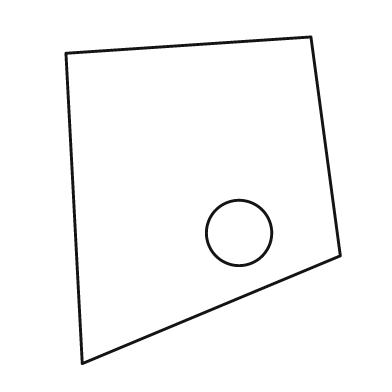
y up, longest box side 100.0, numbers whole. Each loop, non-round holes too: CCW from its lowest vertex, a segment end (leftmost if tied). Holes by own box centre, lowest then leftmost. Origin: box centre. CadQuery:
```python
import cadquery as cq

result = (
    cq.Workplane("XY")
    .moveTo(-37.0, -50.0)
    .lineTo(42.0, -17.0)
    .lineTo(33.0, 50.0)
    .lineTo(-42.0, 45.0)
    .close()
    .moveTo(11.0, -10.0)
    .circle(10.0)
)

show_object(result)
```